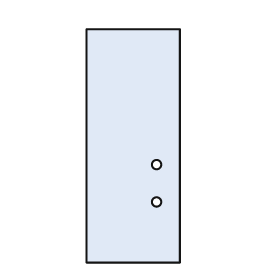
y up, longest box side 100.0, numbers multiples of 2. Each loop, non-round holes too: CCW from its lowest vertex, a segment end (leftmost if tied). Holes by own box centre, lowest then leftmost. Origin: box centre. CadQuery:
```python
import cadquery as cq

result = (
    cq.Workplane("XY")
    .moveTo(-20.0, -50.0)
    .lineTo(20.0, -50.0)
    .lineTo(20.0, 50.0)
    .lineTo(-20.0, 50.0)
    .close()
    .moveTo(10.0, -24.0)
    .circle(2.0)
    .moveTo(10.0, -8.0)
    .circle(2.0)
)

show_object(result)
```